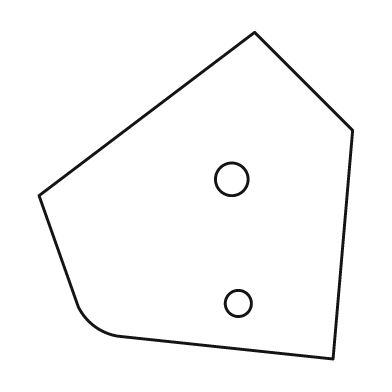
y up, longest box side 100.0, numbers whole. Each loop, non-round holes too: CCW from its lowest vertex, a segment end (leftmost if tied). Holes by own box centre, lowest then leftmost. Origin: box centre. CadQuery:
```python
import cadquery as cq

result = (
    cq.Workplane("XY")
    .moveTo(42.0, -50.0)
    .lineTo(48.0, 20.0)
    .lineTo(18.0, 50.0)
    .lineTo(-48.0, 0.0)
    .lineTo(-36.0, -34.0)
    .threePointArc((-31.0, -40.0), (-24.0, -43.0))
    .close()
    .moveTo(13.0, -33.0)
    .circle(4.0)
    .moveTo(11.0, 5.0)
    .circle(5.0)
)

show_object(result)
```